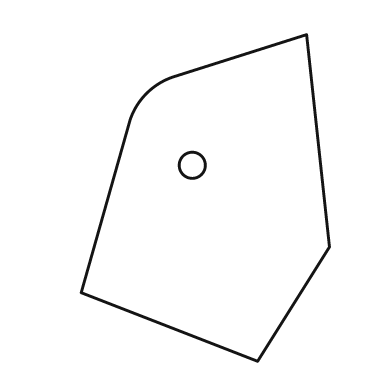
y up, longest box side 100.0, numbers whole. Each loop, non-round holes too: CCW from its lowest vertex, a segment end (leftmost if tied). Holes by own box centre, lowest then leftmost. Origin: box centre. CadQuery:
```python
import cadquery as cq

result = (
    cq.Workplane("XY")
    .moveTo(16.0, -50.0)
    .lineTo(38.0, -15.0)
    .lineTo(31.0, 50.0)
    .lineTo(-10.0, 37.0)
    .threePointArc((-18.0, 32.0), (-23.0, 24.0))
    .lineTo(-38.0, -29.0)
    .close()
    .moveTo(-4.0, 10.0)
    .circle(4.0)
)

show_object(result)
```